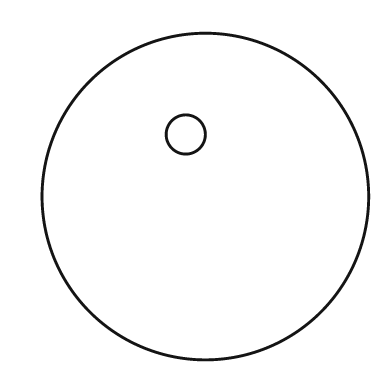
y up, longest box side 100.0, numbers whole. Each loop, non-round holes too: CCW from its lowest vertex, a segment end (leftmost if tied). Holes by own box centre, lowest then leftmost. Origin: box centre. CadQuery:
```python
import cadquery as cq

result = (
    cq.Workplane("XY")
    .moveTo(0.0, 0.0)
    .circle(50.0)
    .moveTo(-6.0, 19.0)
    .circle(6.0)
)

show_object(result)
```